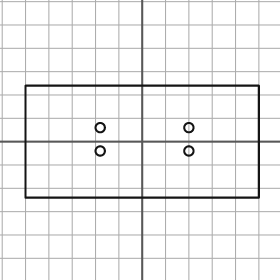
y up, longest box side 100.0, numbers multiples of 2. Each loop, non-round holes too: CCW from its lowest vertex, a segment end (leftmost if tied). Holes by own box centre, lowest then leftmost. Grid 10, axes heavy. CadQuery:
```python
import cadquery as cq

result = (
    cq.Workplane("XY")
    .moveTo(-50.0, -24.0)
    .lineTo(50.0, -24.0)
    .lineTo(50.0, 24.0)
    .lineTo(-50.0, 24.0)
    .close()
    .moveTo(-18.0, -4.0)
    .circle(2.0)
    .moveTo(20.0, -4.0)
    .circle(2.0)
    .moveTo(-18.0, 6.0)
    .circle(2.0)
    .moveTo(20.0, 6.0)
    .circle(2.0)
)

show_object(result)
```